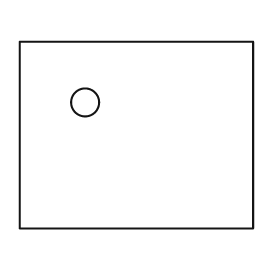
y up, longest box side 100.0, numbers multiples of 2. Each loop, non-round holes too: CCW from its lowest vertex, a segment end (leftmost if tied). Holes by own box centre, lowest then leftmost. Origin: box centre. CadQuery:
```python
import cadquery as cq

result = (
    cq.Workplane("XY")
    .moveTo(-50.0, -40.0)
    .lineTo(50.0, -40.0)
    .lineTo(50.0, 40.0)
    .lineTo(-50.0, 40.0)
    .close()
    .moveTo(-22.0, 14.0)
    .circle(6.0)
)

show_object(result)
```